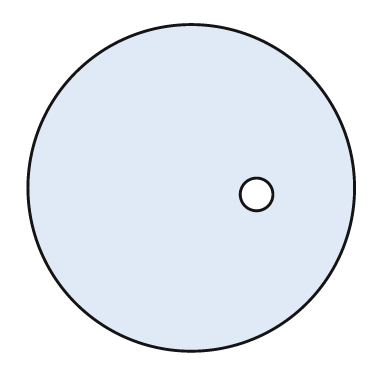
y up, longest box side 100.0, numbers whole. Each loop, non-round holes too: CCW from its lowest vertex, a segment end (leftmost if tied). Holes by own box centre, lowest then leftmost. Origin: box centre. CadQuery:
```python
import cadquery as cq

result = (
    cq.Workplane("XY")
    .moveTo(0.0, 0.0)
    .circle(50.0)
    .moveTo(20.0, -2.0)
    .circle(5.0)
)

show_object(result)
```